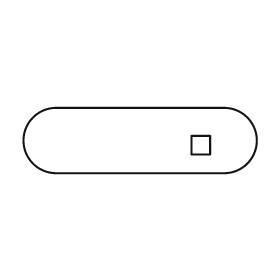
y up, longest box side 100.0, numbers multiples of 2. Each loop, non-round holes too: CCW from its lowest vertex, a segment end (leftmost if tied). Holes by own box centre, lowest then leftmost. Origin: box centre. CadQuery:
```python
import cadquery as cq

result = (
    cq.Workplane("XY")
    .moveTo(-36.0, -14.0)
    .lineTo(36.0, -14.0)
    .threePointArc((50.0, 0.0), (36.0, 14.0))
    .lineTo(-36.0, 14.0)
    .threePointArc((-50.0, 0.0), (-36.0, -14.0))
    .close()
    .moveTo(22.0, -6.0)
    .lineTo(30.0, -6.0)
    .lineTo(30.0, 2.0)
    .lineTo(22.0, 2.0)
    .close()
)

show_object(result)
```